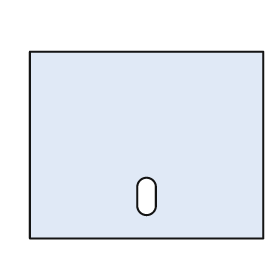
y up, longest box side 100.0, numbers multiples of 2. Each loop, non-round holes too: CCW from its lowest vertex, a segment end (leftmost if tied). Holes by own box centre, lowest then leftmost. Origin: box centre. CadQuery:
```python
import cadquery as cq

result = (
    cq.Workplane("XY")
    .moveTo(-50.0, -40.0)
    .lineTo(50.0, -40.0)
    .lineTo(50.0, 40.0)
    .lineTo(-50.0, 40.0)
    .close()
    .moveTo(-4.0, -26.0)
    .threePointArc((0.0, -30.0), (4.0, -26.0))
    .lineTo(4.0, -18.0)
    .threePointArc((0.0, -14.0), (-4.0, -18.0))
    .close()
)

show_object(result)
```